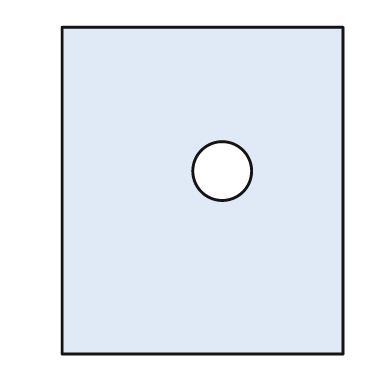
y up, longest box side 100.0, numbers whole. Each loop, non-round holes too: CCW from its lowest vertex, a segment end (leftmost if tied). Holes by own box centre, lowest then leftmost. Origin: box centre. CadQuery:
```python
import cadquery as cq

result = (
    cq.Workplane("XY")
    .moveTo(-43.0, -50.0)
    .lineTo(43.0, -50.0)
    .lineTo(43.0, 50.0)
    .lineTo(-43.0, 50.0)
    .close()
    .moveTo(6.0, 6.0)
    .circle(9.0)
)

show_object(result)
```